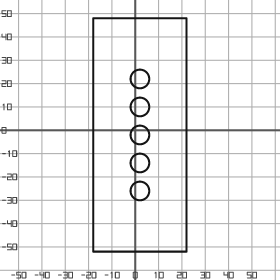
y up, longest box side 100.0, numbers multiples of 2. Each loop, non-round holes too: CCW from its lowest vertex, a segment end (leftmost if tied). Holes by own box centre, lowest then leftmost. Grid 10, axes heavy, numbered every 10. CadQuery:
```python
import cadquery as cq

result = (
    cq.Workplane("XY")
    .moveTo(-18.0, -52.0)
    .lineTo(22.0, -52.0)
    .lineTo(22.0, 48.0)
    .lineTo(-18.0, 48.0)
    .close()
    .moveTo(2.0, -26.0)
    .circle(4.0)
    .moveTo(2.0, -14.0)
    .circle(4.0)
    .moveTo(2.0, -2.0)
    .circle(4.0)
    .moveTo(2.0, 10.0)
    .circle(4.0)
    .moveTo(2.0, 22.0)
    .circle(4.0)
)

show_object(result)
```